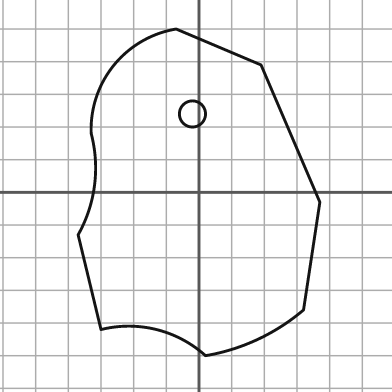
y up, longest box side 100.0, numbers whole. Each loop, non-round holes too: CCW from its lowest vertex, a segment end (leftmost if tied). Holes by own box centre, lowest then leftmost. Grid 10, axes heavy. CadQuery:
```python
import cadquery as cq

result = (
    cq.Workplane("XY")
    .moveTo(2.0, -50.0)
    .threePointArc((18.0, -45.0), (32.0, -36.0))
    .lineTo(37.0, -3.0)
    .lineTo(19.0, 39.0)
    .lineTo(-7.0, 50.0)
    .threePointArc((-26.0, 39.0), (-33.0, 18.0))
    .threePointArc((-32.0, 2.0), (-37.0, -13.0))
    .lineTo(-30.0, -42.0)
    .threePointArc((-13.0, -42.0), (2.0, -50.0))
    .close()
    .moveTo(-2.0, 24.0)
    .circle(4.0)
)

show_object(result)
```